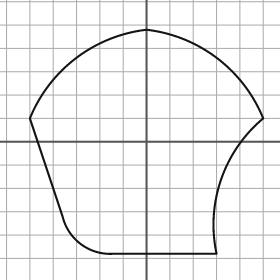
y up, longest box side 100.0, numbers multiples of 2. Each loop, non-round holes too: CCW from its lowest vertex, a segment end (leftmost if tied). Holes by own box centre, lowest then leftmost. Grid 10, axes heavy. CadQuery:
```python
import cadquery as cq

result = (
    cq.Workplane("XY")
    .moveTo(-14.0, -48.0)
    .lineTo(30.0, -48.0)
    .threePointArc((32.0, -16.0), (50.0, 10.0))
    .threePointArc((30.0, 36.0), (0.0, 48.0))
    .threePointArc((-30.0, 36.0), (-50.0, 10.0))
    .lineTo(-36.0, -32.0)
    .threePointArc((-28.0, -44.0), (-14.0, -48.0))
    .close()
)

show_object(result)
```